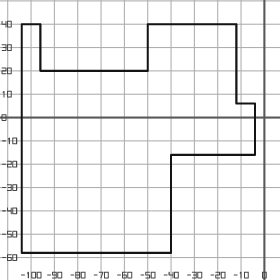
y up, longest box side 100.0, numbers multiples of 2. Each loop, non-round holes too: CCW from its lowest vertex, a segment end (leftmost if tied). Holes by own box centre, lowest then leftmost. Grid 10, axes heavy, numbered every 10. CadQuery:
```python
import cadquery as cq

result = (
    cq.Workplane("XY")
    .moveTo(-104.0, -58.0)
    .lineTo(-40.0, -58.0)
    .lineTo(-40.0, -16.0)
    .lineTo(-4.0, -16.0)
    .lineTo(-4.0, 6.0)
    .lineTo(-12.0, 6.0)
    .lineTo(-12.0, 40.0)
    .lineTo(-50.0, 40.0)
    .lineTo(-50.0, 20.0)
    .lineTo(-96.0, 20.0)
    .lineTo(-96.0, 40.0)
    .lineTo(-104.0, 40.0)
    .close()
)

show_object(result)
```